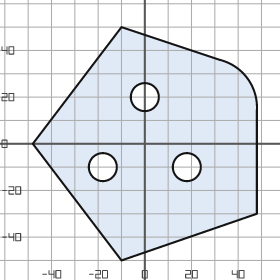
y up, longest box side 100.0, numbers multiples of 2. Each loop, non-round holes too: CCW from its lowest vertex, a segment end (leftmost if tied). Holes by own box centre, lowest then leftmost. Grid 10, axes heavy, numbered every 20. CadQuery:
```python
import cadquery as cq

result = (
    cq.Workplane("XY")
    .moveTo(-10.0, -50.0)
    .lineTo(48.0, -30.0)
    .lineTo(48.0, 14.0)
    .threePointArc((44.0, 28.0), (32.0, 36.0))
    .lineTo(-10.0, 50.0)
    .lineTo(-48.0, 0.0)
    .close()
    .moveTo(-18.0, -10.0)
    .circle(6.0)
    .moveTo(18.0, -10.0)
    .circle(6.0)
    .moveTo(0.0, 20.0)
    .circle(6.0)
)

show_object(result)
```